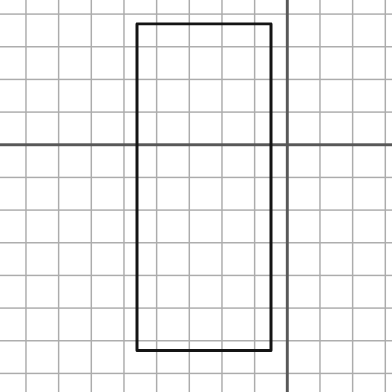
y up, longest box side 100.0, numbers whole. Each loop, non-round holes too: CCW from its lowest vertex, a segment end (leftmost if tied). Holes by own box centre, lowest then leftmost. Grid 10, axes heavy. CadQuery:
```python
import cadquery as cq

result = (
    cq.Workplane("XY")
    .moveTo(-46.0, -63.0)
    .lineTo(-5.0, -63.0)
    .lineTo(-5.0, 37.0)
    .lineTo(-46.0, 37.0)
    .close()
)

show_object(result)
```